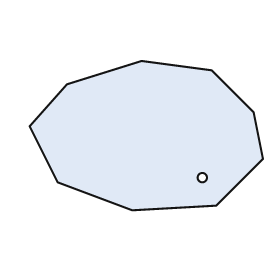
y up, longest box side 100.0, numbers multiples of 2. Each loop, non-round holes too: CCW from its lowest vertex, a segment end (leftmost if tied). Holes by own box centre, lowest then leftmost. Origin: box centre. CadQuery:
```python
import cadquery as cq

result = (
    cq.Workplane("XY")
    .moveTo(-6.0, -32.0)
    .lineTo(30.0, -30.0)
    .lineTo(50.0, -10.0)
    .lineTo(46.0, 10.0)
    .lineTo(28.0, 28.0)
    .lineTo(-2.0, 32.0)
    .lineTo(-34.0, 22.0)
    .lineTo(-50.0, 4.0)
    .lineTo(-38.0, -20.0)
    .close()
    .moveTo(24.0, -18.0)
    .circle(2.0)
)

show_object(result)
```